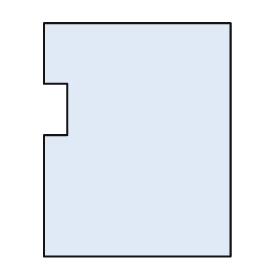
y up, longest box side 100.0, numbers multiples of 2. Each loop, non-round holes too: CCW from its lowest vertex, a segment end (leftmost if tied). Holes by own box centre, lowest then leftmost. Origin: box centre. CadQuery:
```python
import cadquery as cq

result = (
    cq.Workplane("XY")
    .moveTo(-40.0, -50.0)
    .lineTo(40.0, -50.0)
    .lineTo(40.0, 50.0)
    .lineTo(-40.0, 50.0)
    .lineTo(-40.0, 24.0)
    .lineTo(-30.0, 24.0)
    .lineTo(-30.0, 2.0)
    .lineTo(-40.0, 2.0)
    .close()
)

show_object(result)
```